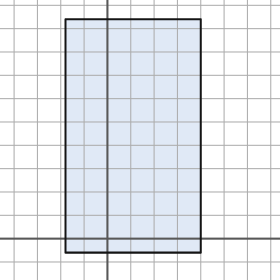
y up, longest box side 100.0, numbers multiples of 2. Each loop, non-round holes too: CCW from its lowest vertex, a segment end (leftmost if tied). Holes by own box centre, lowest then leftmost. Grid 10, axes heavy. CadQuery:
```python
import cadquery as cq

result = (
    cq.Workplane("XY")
    .moveTo(-18.0, -6.0)
    .lineTo(40.0, -6.0)
    .lineTo(40.0, 94.0)
    .lineTo(-18.0, 94.0)
    .close()
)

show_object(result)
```